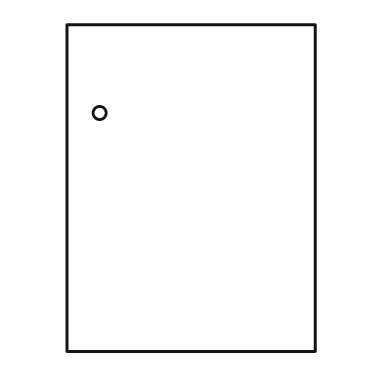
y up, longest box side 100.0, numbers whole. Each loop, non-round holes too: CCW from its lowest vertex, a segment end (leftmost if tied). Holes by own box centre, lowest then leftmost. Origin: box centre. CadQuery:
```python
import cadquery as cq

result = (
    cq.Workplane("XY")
    .moveTo(-38.0, -50.0)
    .lineTo(38.0, -50.0)
    .lineTo(38.0, 50.0)
    .lineTo(-38.0, 50.0)
    .close()
    .moveTo(-28.0, 23.0)
    .circle(2.0)
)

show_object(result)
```